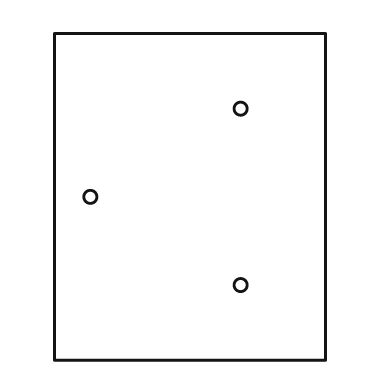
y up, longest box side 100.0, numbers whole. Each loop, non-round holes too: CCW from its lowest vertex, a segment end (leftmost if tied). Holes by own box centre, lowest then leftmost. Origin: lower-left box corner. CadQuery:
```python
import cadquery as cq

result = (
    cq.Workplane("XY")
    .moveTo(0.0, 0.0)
    .lineTo(83.0, 0.0)
    .lineTo(83.0, 100.0)
    .lineTo(0.0, 100.0)
    .close()
    .moveTo(57.0, 23.0)
    .circle(2.0)
    .moveTo(11.0, 50.0)
    .circle(2.0)
    .moveTo(57.0, 77.0)
    .circle(2.0)
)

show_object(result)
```